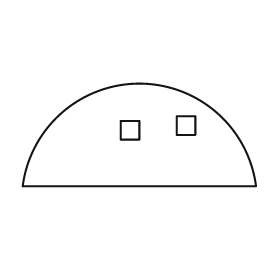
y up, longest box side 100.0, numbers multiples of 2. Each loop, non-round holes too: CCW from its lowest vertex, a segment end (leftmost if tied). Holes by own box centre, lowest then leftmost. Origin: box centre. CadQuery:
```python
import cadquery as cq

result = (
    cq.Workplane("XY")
    .moveTo(-50.0, -22.0)
    .lineTo(50.0, -22.0)
    .threePointArc((0.0, 22.0), (-50.0, -22.0))
    .close()
    .moveTo(-8.0, -2.0)
    .lineTo(0.0, -2.0)
    .lineTo(0.0, 6.0)
    .lineTo(-8.0, 6.0)
    .close()
    .moveTo(16.0, 0.0)
    .lineTo(24.0, 0.0)
    .lineTo(24.0, 8.0)
    .lineTo(16.0, 8.0)
    .close()
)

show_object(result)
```